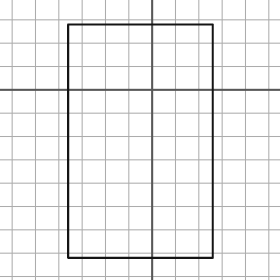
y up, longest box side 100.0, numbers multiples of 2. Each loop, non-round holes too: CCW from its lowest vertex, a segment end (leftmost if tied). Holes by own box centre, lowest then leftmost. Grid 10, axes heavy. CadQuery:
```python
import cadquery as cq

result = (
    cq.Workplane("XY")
    .moveTo(-36.0, -72.0)
    .lineTo(26.0, -72.0)
    .lineTo(26.0, 28.0)
    .lineTo(-36.0, 28.0)
    .close()
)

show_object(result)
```